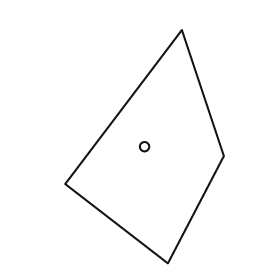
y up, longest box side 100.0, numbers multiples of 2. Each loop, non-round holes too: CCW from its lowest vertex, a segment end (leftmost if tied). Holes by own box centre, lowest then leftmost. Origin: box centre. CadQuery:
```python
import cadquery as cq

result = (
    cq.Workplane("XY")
    .moveTo(10.0, -50.0)
    .lineTo(34.0, -4.0)
    .lineTo(16.0, 50.0)
    .lineTo(-34.0, -16.0)
    .close()
    .moveTo(0.0, 0.0)
    .circle(2.0)
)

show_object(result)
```